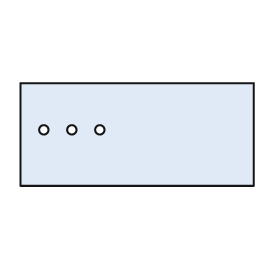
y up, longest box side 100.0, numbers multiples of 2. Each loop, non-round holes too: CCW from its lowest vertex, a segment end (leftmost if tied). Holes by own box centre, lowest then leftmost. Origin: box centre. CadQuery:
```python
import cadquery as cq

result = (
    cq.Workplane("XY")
    .moveTo(-50.0, -22.0)
    .lineTo(50.0, -22.0)
    .lineTo(50.0, 22.0)
    .lineTo(-50.0, 22.0)
    .close()
    .moveTo(-40.0, 2.0)
    .circle(2.0)
    .moveTo(-28.0, 2.0)
    .circle(2.0)
    .moveTo(-16.0, 2.0)
    .circle(2.0)
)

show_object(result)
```